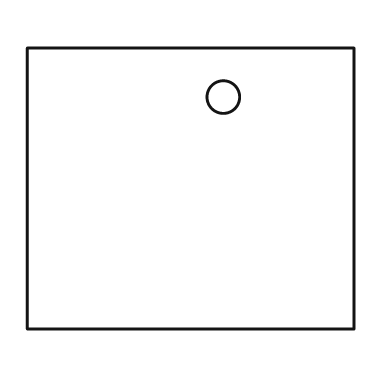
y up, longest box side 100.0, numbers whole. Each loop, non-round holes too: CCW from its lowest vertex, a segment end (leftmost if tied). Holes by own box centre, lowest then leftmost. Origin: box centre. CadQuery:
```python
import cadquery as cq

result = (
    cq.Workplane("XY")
    .moveTo(-50.0, -43.0)
    .lineTo(50.0, -43.0)
    .lineTo(50.0, 43.0)
    .lineTo(-50.0, 43.0)
    .close()
    .moveTo(10.0, 28.0)
    .circle(5.0)
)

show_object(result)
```